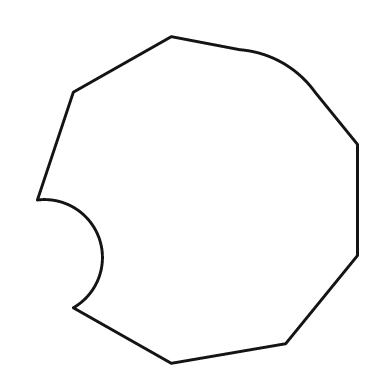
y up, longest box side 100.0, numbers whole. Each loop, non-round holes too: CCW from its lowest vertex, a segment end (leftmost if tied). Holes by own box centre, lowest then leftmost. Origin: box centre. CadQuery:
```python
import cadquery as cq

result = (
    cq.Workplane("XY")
    .moveTo(-8.0, -50.0)
    .lineTo(27.0, -44.0)
    .lineTo(49.0, -17.0)
    .lineTo(49.0, 17.0)
    .lineTo(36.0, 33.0)
    .threePointArc((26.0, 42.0), (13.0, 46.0))
    .lineTo(-8.0, 50.0)
    .lineTo(-38.0, 33.0)
    .lineTo(-49.0, 0.0)
    .threePointArc((-30.0, -12.0), (-38.0, -33.0))
    .close()
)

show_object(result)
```